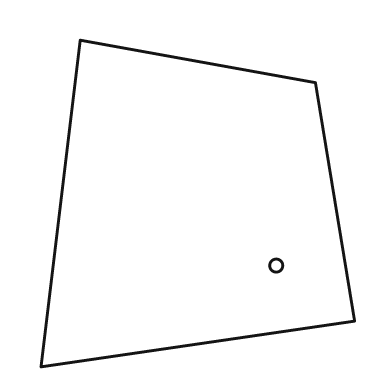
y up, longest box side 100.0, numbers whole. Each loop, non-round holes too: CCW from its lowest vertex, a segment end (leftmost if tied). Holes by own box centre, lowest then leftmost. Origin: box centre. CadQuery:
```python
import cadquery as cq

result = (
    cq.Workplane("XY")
    .moveTo(-48.0, -50.0)
    .lineTo(48.0, -36.0)
    .lineTo(36.0, 37.0)
    .lineTo(-36.0, 50.0)
    .close()
    .moveTo(24.0, -19.0)
    .circle(2.0)
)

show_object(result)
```